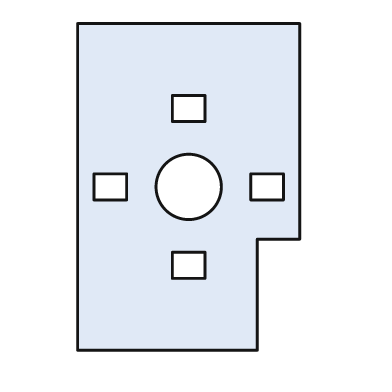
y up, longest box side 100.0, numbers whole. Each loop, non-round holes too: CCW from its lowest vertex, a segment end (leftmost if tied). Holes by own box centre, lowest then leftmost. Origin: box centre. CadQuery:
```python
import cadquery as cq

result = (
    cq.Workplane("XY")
    .moveTo(-34.0, -50.0)
    .lineTo(21.0, -50.0)
    .lineTo(21.0, -16.0)
    .lineTo(34.0, -16.0)
    .lineTo(34.0, 50.0)
    .lineTo(-34.0, 50.0)
    .close()
    .moveTo(-5.0, -28.0)
    .lineTo(5.0, -28.0)
    .lineTo(5.0, -20.0)
    .lineTo(-5.0, -20.0)
    .close()
    .moveTo(-29.0, -4.0)
    .lineTo(-19.0, -4.0)
    .lineTo(-19.0, 4.0)
    .lineTo(-29.0, 4.0)
    .close()
    .moveTo(0.0, 0.0)
    .circle(10.0)
    .moveTo(19.0, -4.0)
    .lineTo(29.0, -4.0)
    .lineTo(29.0, 4.0)
    .lineTo(19.0, 4.0)
    .close()
    .moveTo(-5.0, 20.0)
    .lineTo(5.0, 20.0)
    .lineTo(5.0, 28.0)
    .lineTo(-5.0, 28.0)
    .close()
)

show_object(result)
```